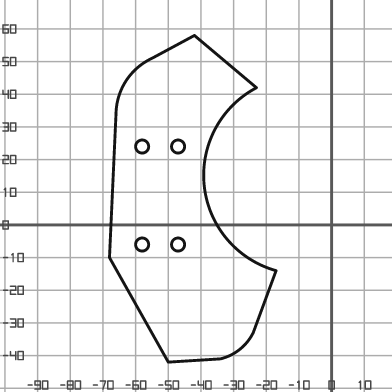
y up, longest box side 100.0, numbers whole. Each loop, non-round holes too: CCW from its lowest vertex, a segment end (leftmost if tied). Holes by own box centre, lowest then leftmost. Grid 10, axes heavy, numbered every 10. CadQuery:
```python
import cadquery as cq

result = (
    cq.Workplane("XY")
    .moveTo(-50.0, -42.0)
    .lineTo(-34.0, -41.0)
    .threePointArc((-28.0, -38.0), (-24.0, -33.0))
    .lineTo(-17.0, -14.0)
    .threePointArc((-39.0, 12.0), (-23.0, 42.0))
    .lineTo(-42.0, 58.0)
    .lineTo(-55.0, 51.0)
    .threePointArc((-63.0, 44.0), (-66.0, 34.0))
    .lineTo(-68.0, -10.0)
    .close()
    .moveTo(-58.0, -6.0)
    .circle(2.0)
    .moveTo(-47.0, -6.0)
    .circle(2.0)
    .moveTo(-58.0, 24.0)
    .circle(2.0)
    .moveTo(-47.0, 24.0)
    .circle(2.0)
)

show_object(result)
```